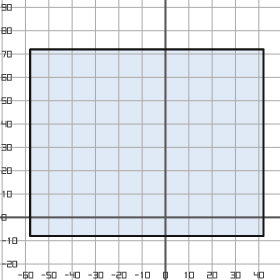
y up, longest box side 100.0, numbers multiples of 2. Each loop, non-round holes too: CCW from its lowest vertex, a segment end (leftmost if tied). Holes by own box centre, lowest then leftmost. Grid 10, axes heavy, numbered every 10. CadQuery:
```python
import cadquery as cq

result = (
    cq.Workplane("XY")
    .moveTo(-58.0, -8.0)
    .lineTo(42.0, -8.0)
    .lineTo(42.0, 72.0)
    .lineTo(-58.0, 72.0)
    .close()
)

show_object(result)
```